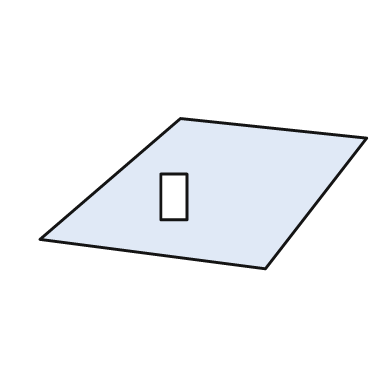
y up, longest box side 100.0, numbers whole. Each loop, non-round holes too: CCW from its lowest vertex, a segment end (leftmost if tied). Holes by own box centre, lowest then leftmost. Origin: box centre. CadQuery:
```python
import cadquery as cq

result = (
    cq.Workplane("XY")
    .moveTo(19.0, -23.0)
    .lineTo(50.0, 17.0)
    .lineTo(-7.0, 23.0)
    .lineTo(-50.0, -14.0)
    .close()
    .moveTo(-13.0, -8.0)
    .lineTo(-5.0, -8.0)
    .lineTo(-5.0, 6.0)
    .lineTo(-13.0, 6.0)
    .close()
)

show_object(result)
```